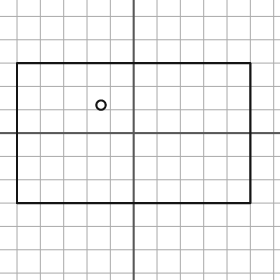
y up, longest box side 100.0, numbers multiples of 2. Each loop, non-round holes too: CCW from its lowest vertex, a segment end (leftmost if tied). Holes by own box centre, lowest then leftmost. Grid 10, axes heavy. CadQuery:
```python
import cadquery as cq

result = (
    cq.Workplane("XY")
    .moveTo(-50.0, -30.0)
    .lineTo(50.0, -30.0)
    .lineTo(50.0, 30.0)
    .lineTo(-50.0, 30.0)
    .close()
    .moveTo(-14.0, 12.0)
    .circle(2.0)
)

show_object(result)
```